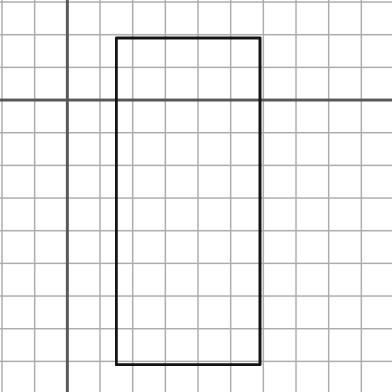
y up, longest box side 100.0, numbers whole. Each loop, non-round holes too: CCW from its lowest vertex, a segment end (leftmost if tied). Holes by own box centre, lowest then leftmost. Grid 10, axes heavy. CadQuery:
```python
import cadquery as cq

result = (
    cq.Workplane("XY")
    .moveTo(15.0, -81.0)
    .lineTo(59.0, -81.0)
    .lineTo(59.0, 19.0)
    .lineTo(15.0, 19.0)
    .close()
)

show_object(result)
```